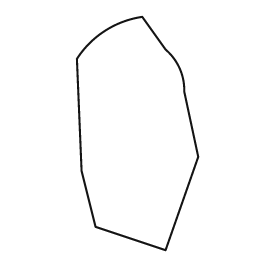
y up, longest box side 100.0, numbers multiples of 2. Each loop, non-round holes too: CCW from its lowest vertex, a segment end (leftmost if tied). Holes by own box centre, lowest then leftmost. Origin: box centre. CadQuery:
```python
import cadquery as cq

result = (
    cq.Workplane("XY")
    .moveTo(12.0, -50.0)
    .lineTo(26.0, -10.0)
    .lineTo(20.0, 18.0)
    .threePointArc((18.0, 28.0), (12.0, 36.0))
    .lineTo(2.0, 50.0)
    .threePointArc((-14.0, 44.0), (-26.0, 32.0))
    .lineTo(-24.0, -16.0)
    .lineTo(-18.0, -40.0)
    .close()
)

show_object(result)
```